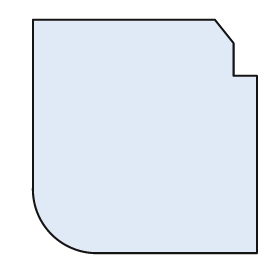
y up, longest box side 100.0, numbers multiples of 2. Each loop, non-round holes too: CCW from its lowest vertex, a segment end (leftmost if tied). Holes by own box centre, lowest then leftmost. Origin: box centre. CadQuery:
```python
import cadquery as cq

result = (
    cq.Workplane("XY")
    .moveTo(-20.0, -50.0)
    .lineTo(48.0, -50.0)
    .lineTo(48.0, 26.0)
    .lineTo(38.0, 26.0)
    .lineTo(38.0, 40.0)
    .lineTo(30.0, 50.0)
    .lineTo(-48.0, 50.0)
    .lineTo(-48.0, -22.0)
    .threePointArc((-40.0, -42.0), (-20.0, -50.0))
    .close()
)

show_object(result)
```